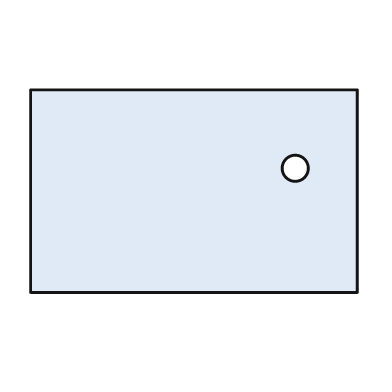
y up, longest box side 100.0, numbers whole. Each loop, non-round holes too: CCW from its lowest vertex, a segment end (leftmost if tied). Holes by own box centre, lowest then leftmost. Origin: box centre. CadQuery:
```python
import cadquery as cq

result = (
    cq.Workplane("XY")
    .moveTo(-50.0, -31.0)
    .lineTo(50.0, -31.0)
    .lineTo(50.0, 31.0)
    .lineTo(-50.0, 31.0)
    .close()
    .moveTo(31.0, 7.0)
    .circle(4.0)
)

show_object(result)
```